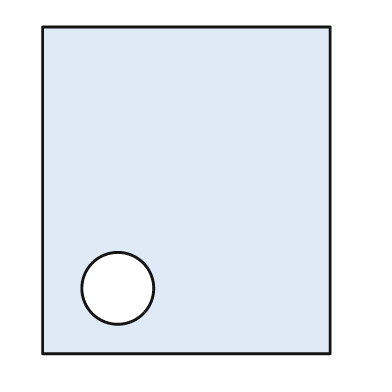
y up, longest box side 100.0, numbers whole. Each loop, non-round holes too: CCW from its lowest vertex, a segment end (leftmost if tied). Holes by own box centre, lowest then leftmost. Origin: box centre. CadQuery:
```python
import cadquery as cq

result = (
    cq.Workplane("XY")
    .moveTo(-44.0, -50.0)
    .lineTo(44.0, -50.0)
    .lineTo(44.0, 50.0)
    .lineTo(-44.0, 50.0)
    .close()
    .moveTo(-21.0, -30.0)
    .circle(11.0)
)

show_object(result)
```